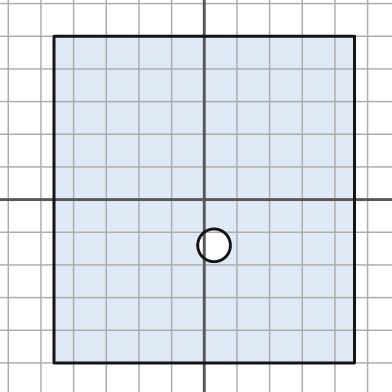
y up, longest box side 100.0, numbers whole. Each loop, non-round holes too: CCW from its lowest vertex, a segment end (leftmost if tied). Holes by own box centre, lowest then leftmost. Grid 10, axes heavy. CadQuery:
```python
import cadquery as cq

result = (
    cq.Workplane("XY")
    .moveTo(-46.0, -50.0)
    .lineTo(46.0, -50.0)
    .lineTo(46.0, 50.0)
    .lineTo(-46.0, 50.0)
    .close()
    .moveTo(3.0, -14.0)
    .circle(5.0)
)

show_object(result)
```